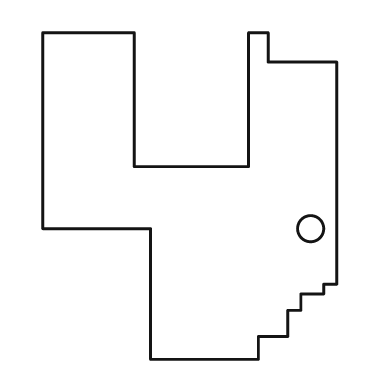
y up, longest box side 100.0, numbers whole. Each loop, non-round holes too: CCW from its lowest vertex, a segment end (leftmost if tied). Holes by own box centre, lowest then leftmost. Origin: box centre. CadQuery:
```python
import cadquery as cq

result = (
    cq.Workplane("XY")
    .moveTo(-12.0, -50.0)
    .lineTo(21.0, -50.0)
    .lineTo(21.0, -43.0)
    .lineTo(30.0, -43.0)
    .lineTo(30.0, -35.0)
    .lineTo(34.0, -35.0)
    .lineTo(34.0, -30.0)
    .lineTo(41.0, -30.0)
    .lineTo(41.0, -27.0)
    .lineTo(45.0, -27.0)
    .lineTo(45.0, 41.0)
    .lineTo(24.0, 41.0)
    .lineTo(24.0, 50.0)
    .lineTo(18.0, 50.0)
    .lineTo(18.0, 9.0)
    .lineTo(-17.0, 9.0)
    .lineTo(-17.0, 50.0)
    .lineTo(-45.0, 50.0)
    .lineTo(-45.0, -10.0)
    .lineTo(-12.0, -10.0)
    .close()
    .moveTo(37.0, -10.0)
    .circle(4.0)
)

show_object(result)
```